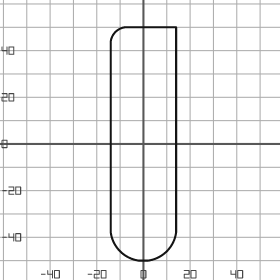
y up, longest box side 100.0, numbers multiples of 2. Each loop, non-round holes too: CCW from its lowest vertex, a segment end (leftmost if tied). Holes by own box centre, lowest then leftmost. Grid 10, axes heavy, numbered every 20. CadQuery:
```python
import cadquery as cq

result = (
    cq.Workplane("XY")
    .moveTo(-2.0, -50.0)
    .lineTo(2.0, -50.0)
    .threePointArc((10.0, -46.0), (14.0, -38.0))
    .lineTo(14.0, 50.0)
    .lineTo(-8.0, 50.0)
    .threePointArc((-12.0, 48.0), (-14.0, 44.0))
    .lineTo(-14.0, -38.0)
    .threePointArc((-10.0, -46.0), (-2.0, -50.0))
    .close()
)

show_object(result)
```